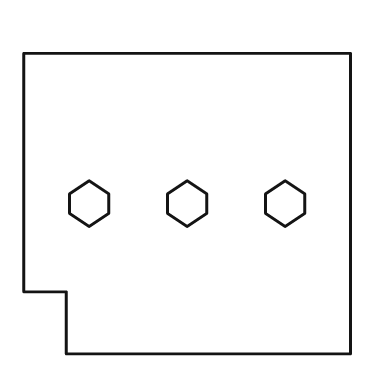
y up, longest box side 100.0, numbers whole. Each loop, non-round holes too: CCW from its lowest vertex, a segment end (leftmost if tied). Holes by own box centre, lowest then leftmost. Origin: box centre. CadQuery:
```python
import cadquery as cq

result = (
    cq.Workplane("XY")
    .moveTo(-37.0, -46.0)
    .lineTo(50.0, -46.0)
    .lineTo(50.0, 46.0)
    .lineTo(-50.0, 46.0)
    .lineTo(-50.0, -27.0)
    .lineTo(-37.0, -27.0)
    .close()
    .moveTo(-30.0, -7.0)
    .lineTo(-24.0, -3.0)
    .lineTo(-24.0, 3.0)
    .lineTo(-30.0, 7.0)
    .lineTo(-36.0, 3.0)
    .lineTo(-36.0, -3.0)
    .close()
    .moveTo(0.0, -7.0)
    .lineTo(6.0, -3.0)
    .lineTo(6.0, 3.0)
    .lineTo(0.0, 7.0)
    .lineTo(-6.0, 3.0)
    .lineTo(-6.0, -3.0)
    .close()
    .moveTo(30.0, -7.0)
    .lineTo(36.0, -3.0)
    .lineTo(36.0, 3.0)
    .lineTo(30.0, 7.0)
    .lineTo(24.0, 3.0)
    .lineTo(24.0, -3.0)
    .close()
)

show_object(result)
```